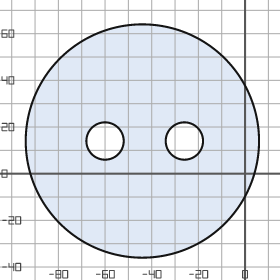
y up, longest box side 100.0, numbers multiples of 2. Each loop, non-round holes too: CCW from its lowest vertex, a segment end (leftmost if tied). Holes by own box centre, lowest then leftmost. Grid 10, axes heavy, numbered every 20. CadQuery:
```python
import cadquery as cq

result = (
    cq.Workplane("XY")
    .moveTo(-44.0, 14.0)
    .circle(50.0)
    .moveTo(-60.0, 14.0)
    .circle(8.0)
    .moveTo(-26.0, 14.0)
    .circle(8.0)
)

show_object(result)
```